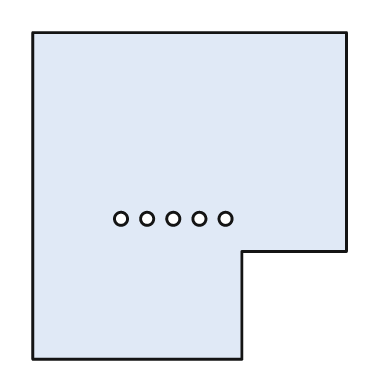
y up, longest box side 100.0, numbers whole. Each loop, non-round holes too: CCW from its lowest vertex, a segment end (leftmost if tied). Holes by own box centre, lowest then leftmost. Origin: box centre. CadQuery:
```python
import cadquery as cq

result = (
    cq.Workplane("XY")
    .moveTo(-48.0, -50.0)
    .lineTo(16.0, -50.0)
    .lineTo(16.0, -17.0)
    .lineTo(48.0, -17.0)
    .lineTo(48.0, 50.0)
    .lineTo(-48.0, 50.0)
    .close()
    .moveTo(-21.0, -7.0)
    .circle(2.0)
    .moveTo(-13.0, -7.0)
    .circle(2.0)
    .moveTo(-5.0, -7.0)
    .circle(2.0)
    .moveTo(3.0, -7.0)
    .circle(2.0)
    .moveTo(11.0, -7.0)
    .circle(2.0)
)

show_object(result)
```